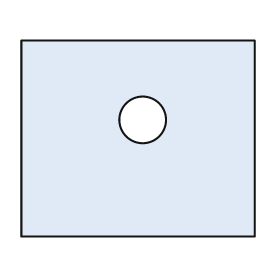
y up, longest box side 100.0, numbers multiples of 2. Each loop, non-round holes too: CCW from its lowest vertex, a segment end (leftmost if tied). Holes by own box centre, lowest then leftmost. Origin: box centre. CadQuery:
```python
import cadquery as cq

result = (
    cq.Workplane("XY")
    .moveTo(-50.0, -42.0)
    .lineTo(50.0, -42.0)
    .lineTo(50.0, 42.0)
    .lineTo(-50.0, 42.0)
    .close()
    .moveTo(2.0, 8.0)
    .circle(10.0)
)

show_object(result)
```